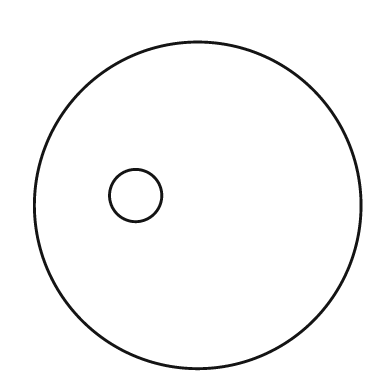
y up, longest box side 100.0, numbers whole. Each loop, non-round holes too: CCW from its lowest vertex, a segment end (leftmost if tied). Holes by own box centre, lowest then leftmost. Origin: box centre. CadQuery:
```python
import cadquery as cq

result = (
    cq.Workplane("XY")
    .moveTo(0.0, 0.0)
    .circle(50.0)
    .moveTo(-19.0, 3.0)
    .circle(8.0)
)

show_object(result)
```